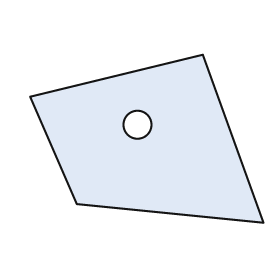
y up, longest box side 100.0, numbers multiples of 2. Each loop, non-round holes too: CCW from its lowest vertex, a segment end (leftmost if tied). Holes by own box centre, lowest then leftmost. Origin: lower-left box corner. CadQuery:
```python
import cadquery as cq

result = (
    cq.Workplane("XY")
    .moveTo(100.0, 0.0)
    .lineTo(74.0, 72.0)
    .lineTo(0.0, 54.0)
    .lineTo(20.0, 8.0)
    .close()
    .moveTo(46.0, 42.0)
    .circle(6.0)
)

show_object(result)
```